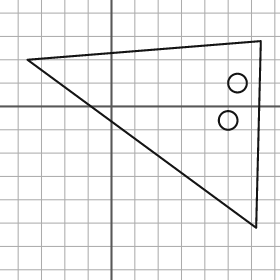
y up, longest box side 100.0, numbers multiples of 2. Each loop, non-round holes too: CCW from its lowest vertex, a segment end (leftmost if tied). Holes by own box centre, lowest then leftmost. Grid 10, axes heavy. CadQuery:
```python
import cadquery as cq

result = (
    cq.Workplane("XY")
    .moveTo(62.0, -52.0)
    .lineTo(64.0, 28.0)
    .lineTo(-36.0, 20.0)
    .close()
    .moveTo(50.0, -6.0)
    .circle(4.0)
    .moveTo(54.0, 10.0)
    .circle(4.0)
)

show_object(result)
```